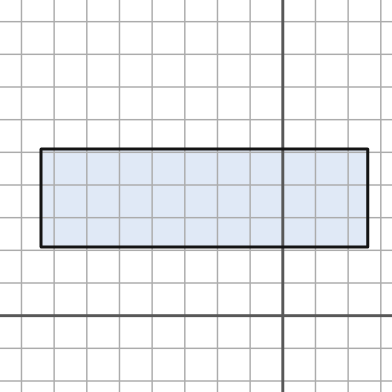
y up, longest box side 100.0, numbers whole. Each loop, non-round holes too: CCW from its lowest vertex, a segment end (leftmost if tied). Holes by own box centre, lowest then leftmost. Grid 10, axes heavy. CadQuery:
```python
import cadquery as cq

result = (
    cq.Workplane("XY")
    .moveTo(-74.0, 21.0)
    .lineTo(26.0, 21.0)
    .lineTo(26.0, 51.0)
    .lineTo(-74.0, 51.0)
    .close()
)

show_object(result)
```